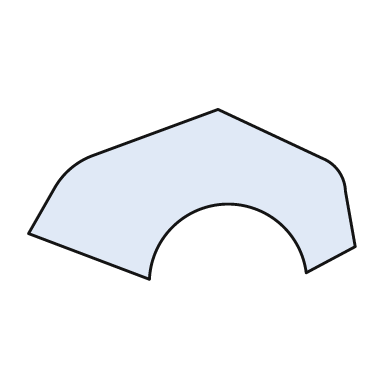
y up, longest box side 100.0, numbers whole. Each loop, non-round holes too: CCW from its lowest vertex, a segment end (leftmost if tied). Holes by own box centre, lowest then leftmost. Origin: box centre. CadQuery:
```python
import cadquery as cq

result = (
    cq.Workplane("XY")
    .moveTo(-13.0, -26.0)
    .threePointArc((10.0, -3.0), (35.0, -24.0))
    .lineTo(50.0, -16.0)
    .lineTo(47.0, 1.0)
    .threePointArc((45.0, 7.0), (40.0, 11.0))
    .lineTo(8.0, 26.0)
    .lineTo(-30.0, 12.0)
    .threePointArc((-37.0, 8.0), (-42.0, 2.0))
    .lineTo(-50.0, -12.0)
    .close()
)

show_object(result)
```